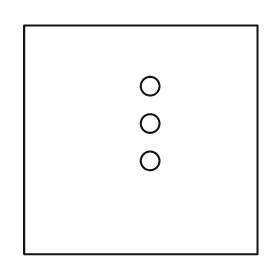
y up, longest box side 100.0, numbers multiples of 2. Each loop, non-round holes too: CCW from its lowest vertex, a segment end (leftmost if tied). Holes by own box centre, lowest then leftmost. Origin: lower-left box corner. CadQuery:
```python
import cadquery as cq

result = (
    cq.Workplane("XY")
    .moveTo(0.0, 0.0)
    .lineTo(100.0, 0.0)
    .lineTo(100.0, 98.0)
    .lineTo(0.0, 98.0)
    .close()
    .moveTo(54.0, 40.0)
    .circle(4.0)
    .moveTo(54.0, 56.0)
    .circle(4.0)
    .moveTo(54.0, 72.0)
    .circle(4.0)
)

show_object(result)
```